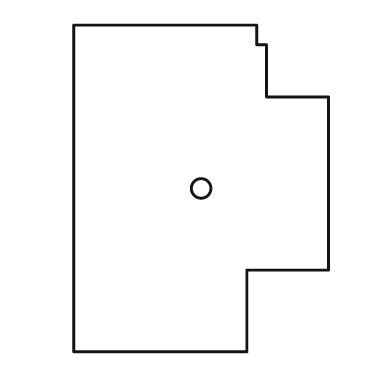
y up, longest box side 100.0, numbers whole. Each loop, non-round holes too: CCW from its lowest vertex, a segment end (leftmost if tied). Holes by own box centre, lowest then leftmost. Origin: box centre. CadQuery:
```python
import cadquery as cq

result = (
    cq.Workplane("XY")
    .moveTo(-39.0, -50.0)
    .lineTo(14.0, -50.0)
    .lineTo(14.0, -25.0)
    .lineTo(39.0, -25.0)
    .lineTo(39.0, 28.0)
    .lineTo(20.0, 28.0)
    .lineTo(20.0, 44.0)
    .lineTo(17.0, 44.0)
    .lineTo(17.0, 50.0)
    .lineTo(-39.0, 50.0)
    .close()
    .moveTo(0.0, 0.0)
    .circle(3.0)
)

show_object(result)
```